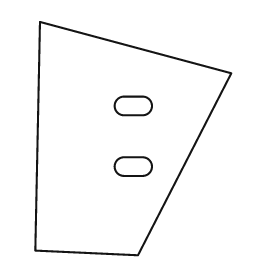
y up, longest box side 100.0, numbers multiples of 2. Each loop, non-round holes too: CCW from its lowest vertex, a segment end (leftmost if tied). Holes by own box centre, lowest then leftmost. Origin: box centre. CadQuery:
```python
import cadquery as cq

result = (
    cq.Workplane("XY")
    .moveTo(2.0, -50.0)
    .lineTo(42.0, 28.0)
    .lineTo(-40.0, 50.0)
    .lineTo(-42.0, -48.0)
    .close()
    .moveTo(-4.0, -16.0)
    .lineTo(4.0, -16.0)
    .threePointArc((8.0, -12.0), (4.0, -8.0))
    .lineTo(-4.0, -8.0)
    .threePointArc((-8.0, -12.0), (-4.0, -16.0))
    .close()
    .moveTo(-4.0, 10.0)
    .lineTo(4.0, 10.0)
    .threePointArc((8.0, 14.0), (4.0, 18.0))
    .lineTo(-4.0, 18.0)
    .threePointArc((-8.0, 14.0), (-4.0, 10.0))
    .close()
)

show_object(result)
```